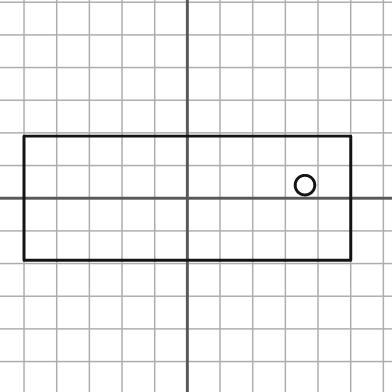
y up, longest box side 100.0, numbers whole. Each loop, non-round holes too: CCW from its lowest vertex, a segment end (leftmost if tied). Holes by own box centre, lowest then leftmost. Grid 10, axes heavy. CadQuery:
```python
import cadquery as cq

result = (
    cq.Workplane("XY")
    .moveTo(-50.0, -19.0)
    .lineTo(50.0, -19.0)
    .lineTo(50.0, 19.0)
    .lineTo(-50.0, 19.0)
    .close()
    .moveTo(36.0, 4.0)
    .circle(3.0)
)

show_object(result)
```